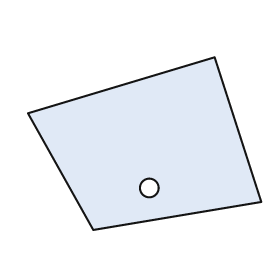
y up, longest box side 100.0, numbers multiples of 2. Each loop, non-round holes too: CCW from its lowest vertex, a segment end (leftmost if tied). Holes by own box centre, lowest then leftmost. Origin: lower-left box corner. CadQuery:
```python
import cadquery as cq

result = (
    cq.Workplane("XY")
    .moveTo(28.0, 0.0)
    .lineTo(100.0, 12.0)
    .lineTo(80.0, 74.0)
    .lineTo(0.0, 50.0)
    .close()
    .moveTo(52.0, 18.0)
    .circle(4.0)
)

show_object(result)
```